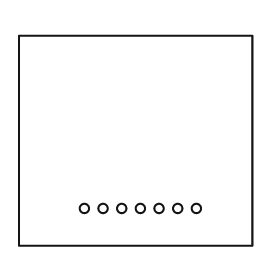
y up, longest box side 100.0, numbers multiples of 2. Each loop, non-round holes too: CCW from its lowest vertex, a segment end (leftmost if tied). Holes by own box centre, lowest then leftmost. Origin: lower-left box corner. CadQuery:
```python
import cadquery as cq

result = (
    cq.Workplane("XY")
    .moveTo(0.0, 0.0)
    .lineTo(100.0, 0.0)
    .lineTo(100.0, 90.0)
    .lineTo(0.0, 90.0)
    .close()
    .moveTo(28.0, 16.0)
    .circle(2.0)
    .moveTo(36.0, 16.0)
    .circle(2.0)
    .moveTo(44.0, 16.0)
    .circle(2.0)
    .moveTo(52.0, 16.0)
    .circle(2.0)
    .moveTo(60.0, 16.0)
    .circle(2.0)
    .moveTo(68.0, 16.0)
    .circle(2.0)
    .moveTo(76.0, 16.0)
    .circle(2.0)
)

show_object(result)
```